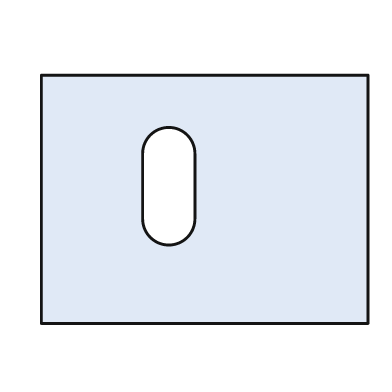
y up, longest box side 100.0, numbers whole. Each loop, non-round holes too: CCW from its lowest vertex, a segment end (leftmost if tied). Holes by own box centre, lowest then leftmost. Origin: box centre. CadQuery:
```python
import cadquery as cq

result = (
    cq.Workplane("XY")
    .moveTo(-50.0, -38.0)
    .lineTo(50.0, -38.0)
    .lineTo(50.0, 38.0)
    .lineTo(-50.0, 38.0)
    .close()
    .moveTo(-19.0, -6.0)
    .threePointArc((-11.0, -14.0), (-3.0, -6.0))
    .lineTo(-3.0, 14.0)
    .threePointArc((-11.0, 22.0), (-19.0, 14.0))
    .close()
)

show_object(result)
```